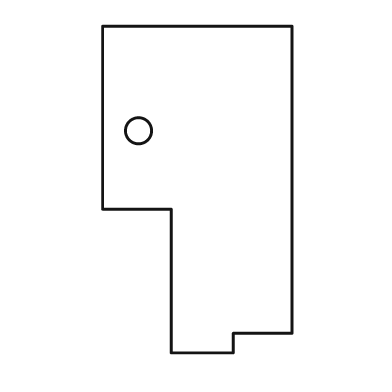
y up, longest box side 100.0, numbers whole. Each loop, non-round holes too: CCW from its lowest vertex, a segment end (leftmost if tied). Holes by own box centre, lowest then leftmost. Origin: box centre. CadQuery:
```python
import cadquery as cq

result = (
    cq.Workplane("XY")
    .moveTo(-8.0, -50.0)
    .lineTo(11.0, -50.0)
    .lineTo(11.0, -44.0)
    .lineTo(29.0, -44.0)
    .lineTo(29.0, 50.0)
    .lineTo(-29.0, 50.0)
    .lineTo(-29.0, -6.0)
    .lineTo(-8.0, -6.0)
    .close()
    .moveTo(-18.0, 18.0)
    .circle(4.0)
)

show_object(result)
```